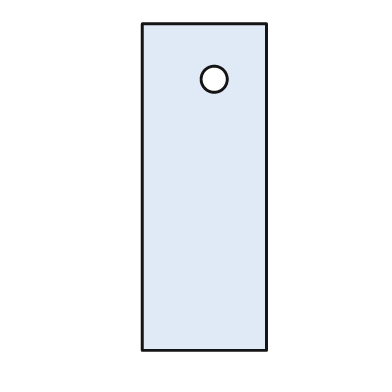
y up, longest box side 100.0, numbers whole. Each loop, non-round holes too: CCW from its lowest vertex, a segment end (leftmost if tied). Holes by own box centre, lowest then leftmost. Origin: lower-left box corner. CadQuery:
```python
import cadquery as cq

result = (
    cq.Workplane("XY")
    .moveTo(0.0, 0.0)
    .lineTo(38.0, 0.0)
    .lineTo(38.0, 100.0)
    .lineTo(0.0, 100.0)
    .close()
    .moveTo(22.0, 83.0)
    .circle(4.0)
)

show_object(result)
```